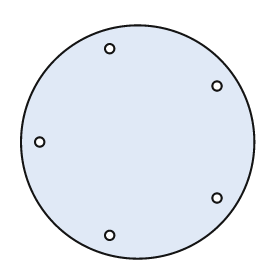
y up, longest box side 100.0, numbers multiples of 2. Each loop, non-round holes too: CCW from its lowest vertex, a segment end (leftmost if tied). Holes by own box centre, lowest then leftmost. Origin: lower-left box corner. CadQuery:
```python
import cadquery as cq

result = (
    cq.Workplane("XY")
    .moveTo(50.0, 50.0)
    .circle(50.0)
    .moveTo(38.0, 10.0)
    .circle(2.0)
    .moveTo(84.0, 26.0)
    .circle(2.0)
    .moveTo(8.0, 50.0)
    .circle(2.0)
    .moveTo(84.0, 74.0)
    .circle(2.0)
    .moveTo(38.0, 90.0)
    .circle(2.0)
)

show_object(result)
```